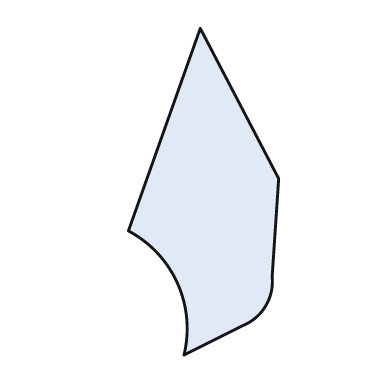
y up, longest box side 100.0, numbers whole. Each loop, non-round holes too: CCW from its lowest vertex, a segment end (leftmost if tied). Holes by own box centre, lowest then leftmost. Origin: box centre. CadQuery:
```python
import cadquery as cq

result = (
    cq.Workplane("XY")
    .moveTo(-6.0, -50.0)
    .lineTo(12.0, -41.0)
    .threePointArc((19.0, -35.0), (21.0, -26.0))
    .lineTo(23.0, 4.0)
    .lineTo(-1.0, 50.0)
    .lineTo(-23.0, -12.0)
    .threePointArc((-8.0, -28.0), (-6.0, -50.0))
    .close()
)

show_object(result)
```